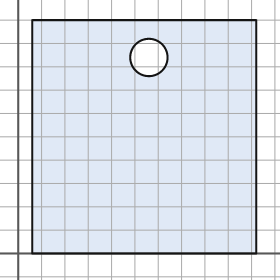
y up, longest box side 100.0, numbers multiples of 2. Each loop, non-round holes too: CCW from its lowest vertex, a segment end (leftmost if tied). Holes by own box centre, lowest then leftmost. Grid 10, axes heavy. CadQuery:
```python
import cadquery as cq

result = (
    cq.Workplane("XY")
    .moveTo(6.0, 0.0)
    .lineTo(102.0, 0.0)
    .lineTo(102.0, 100.0)
    .lineTo(6.0, 100.0)
    .close()
    .moveTo(56.0, 84.0)
    .circle(8.0)
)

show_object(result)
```